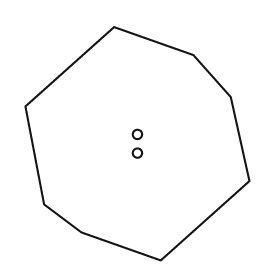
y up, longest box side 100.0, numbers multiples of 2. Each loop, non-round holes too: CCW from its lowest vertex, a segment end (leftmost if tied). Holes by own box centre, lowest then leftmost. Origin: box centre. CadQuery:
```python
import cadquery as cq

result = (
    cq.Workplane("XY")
    .moveTo(10.0, -50.0)
    .lineTo(48.0, -16.0)
    .lineTo(40.0, 20.0)
    .lineTo(24.0, 38.0)
    .lineTo(-10.0, 50.0)
    .lineTo(-48.0, 16.0)
    .lineTo(-40.0, -26.0)
    .lineTo(-24.0, -38.0)
    .close()
    .moveTo(0.0, -4.0)
    .circle(2.0)
    .moveTo(0.0, 4.0)
    .circle(2.0)
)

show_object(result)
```